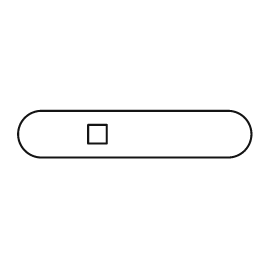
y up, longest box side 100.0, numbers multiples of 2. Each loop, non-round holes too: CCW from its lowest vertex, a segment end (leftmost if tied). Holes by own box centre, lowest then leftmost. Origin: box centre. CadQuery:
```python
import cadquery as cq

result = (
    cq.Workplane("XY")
    .moveTo(-40.0, -10.0)
    .lineTo(40.0, -10.0)
    .threePointArc((50.0, 0.0), (40.0, 10.0))
    .lineTo(-40.0, 10.0)
    .threePointArc((-50.0, 0.0), (-40.0, -10.0))
    .close()
    .moveTo(-20.0, -4.0)
    .lineTo(-12.0, -4.0)
    .lineTo(-12.0, 4.0)
    .lineTo(-20.0, 4.0)
    .close()
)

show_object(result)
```